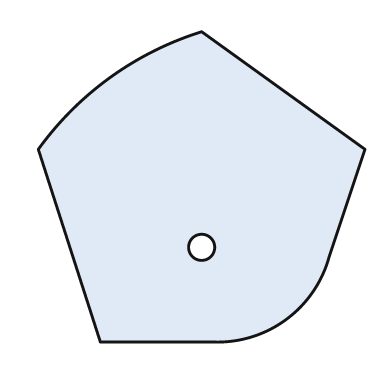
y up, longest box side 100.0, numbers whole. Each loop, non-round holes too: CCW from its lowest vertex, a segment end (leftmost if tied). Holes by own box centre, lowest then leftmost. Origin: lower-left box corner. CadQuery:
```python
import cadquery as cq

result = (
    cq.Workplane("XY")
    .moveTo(19.0, 0.0)
    .lineTo(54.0, 0.0)
    .threePointArc((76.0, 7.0), (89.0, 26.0))
    .lineTo(100.0, 59.0)
    .lineTo(50.0, 95.0)
    .threePointArc((22.0, 81.0), (0.0, 59.0))
    .close()
    .moveTo(50.0, 29.0)
    .circle(4.0)
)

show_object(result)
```